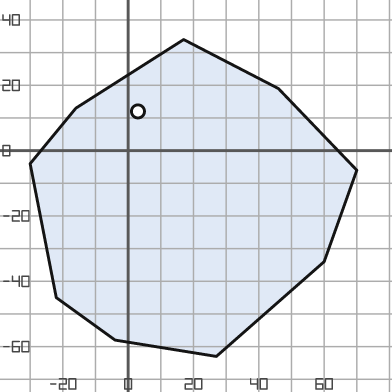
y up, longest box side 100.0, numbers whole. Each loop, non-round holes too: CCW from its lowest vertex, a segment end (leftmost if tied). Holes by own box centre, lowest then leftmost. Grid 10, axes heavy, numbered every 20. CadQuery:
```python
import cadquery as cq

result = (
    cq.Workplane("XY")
    .moveTo(27.0, -63.0)
    .lineTo(60.0, -34.0)
    .lineTo(70.0, -6.0)
    .lineTo(46.0, 19.0)
    .lineTo(17.0, 34.0)
    .lineTo(-16.0, 13.0)
    .lineTo(-30.0, -4.0)
    .lineTo(-22.0, -45.0)
    .lineTo(-4.0, -58.0)
    .close()
    .moveTo(3.0, 12.0)
    .circle(2.0)
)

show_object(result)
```